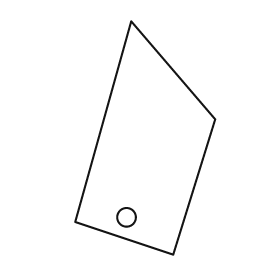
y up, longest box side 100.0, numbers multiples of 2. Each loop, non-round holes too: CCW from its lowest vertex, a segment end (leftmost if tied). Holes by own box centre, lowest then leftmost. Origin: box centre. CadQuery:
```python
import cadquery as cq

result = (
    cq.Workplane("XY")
    .moveTo(12.0, -50.0)
    .lineTo(30.0, 8.0)
    .lineTo(-6.0, 50.0)
    .lineTo(-30.0, -36.0)
    .close()
    .moveTo(-8.0, -34.0)
    .circle(4.0)
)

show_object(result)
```